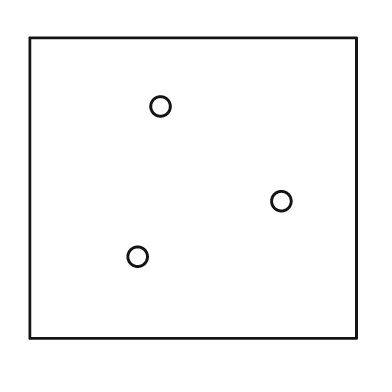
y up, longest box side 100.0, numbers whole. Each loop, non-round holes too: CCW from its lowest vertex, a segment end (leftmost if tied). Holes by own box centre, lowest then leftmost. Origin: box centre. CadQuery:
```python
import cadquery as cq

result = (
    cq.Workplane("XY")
    .moveTo(-50.0, -46.0)
    .lineTo(50.0, -46.0)
    .lineTo(50.0, 46.0)
    .lineTo(-50.0, 46.0)
    .close()
    .moveTo(-17.0, -21.0)
    .circle(3.0)
    .moveTo(27.0, -4.0)
    .circle(3.0)
    .moveTo(-10.0, 25.0)
    .circle(3.0)
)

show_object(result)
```